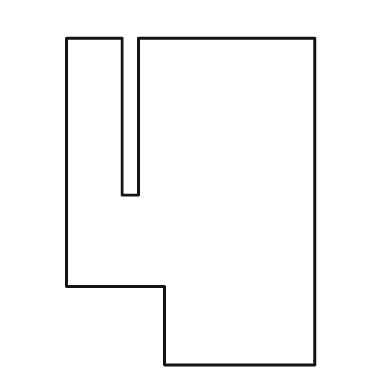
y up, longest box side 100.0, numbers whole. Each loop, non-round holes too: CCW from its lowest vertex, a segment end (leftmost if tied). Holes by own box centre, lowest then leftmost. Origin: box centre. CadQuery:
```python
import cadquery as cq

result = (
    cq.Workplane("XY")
    .moveTo(-8.0, -50.0)
    .lineTo(38.0, -50.0)
    .lineTo(38.0, 50.0)
    .lineTo(-16.0, 50.0)
    .lineTo(-16.0, 2.0)
    .lineTo(-21.0, 2.0)
    .lineTo(-21.0, 50.0)
    .lineTo(-38.0, 50.0)
    .lineTo(-38.0, -26.0)
    .lineTo(-8.0, -26.0)
    .close()
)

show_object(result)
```